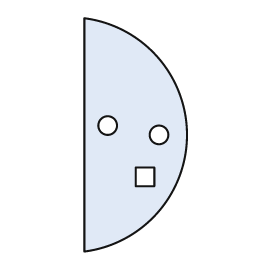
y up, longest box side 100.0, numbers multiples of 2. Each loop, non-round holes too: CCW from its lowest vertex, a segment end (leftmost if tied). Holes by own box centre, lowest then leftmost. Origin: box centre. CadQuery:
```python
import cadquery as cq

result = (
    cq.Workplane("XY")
    .moveTo(-22.0, -50.0)
    .threePointArc((22.0, 0.0), (-22.0, 50.0))
    .close()
    .moveTo(0.0, -22.0)
    .lineTo(8.0, -22.0)
    .lineTo(8.0, -14.0)
    .lineTo(0.0, -14.0)
    .close()
    .moveTo(10.0, 0.0)
    .circle(4.0)
    .moveTo(-12.0, 4.0)
    .circle(4.0)
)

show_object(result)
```